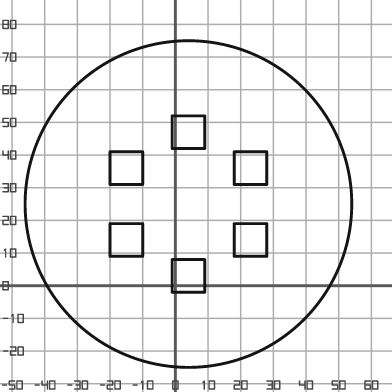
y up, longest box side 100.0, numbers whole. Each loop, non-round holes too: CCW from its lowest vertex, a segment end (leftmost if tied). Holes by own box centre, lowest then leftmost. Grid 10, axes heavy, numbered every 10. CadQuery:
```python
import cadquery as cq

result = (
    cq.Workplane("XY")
    .moveTo(4.0, 25.0)
    .circle(50.0)
    .moveTo(-1.0, -2.0)
    .lineTo(9.0, -2.0)
    .lineTo(9.0, 8.0)
    .lineTo(-1.0, 8.0)
    .close()
    .moveTo(-20.0, 9.0)
    .lineTo(-10.0, 9.0)
    .lineTo(-10.0, 19.0)
    .lineTo(-20.0, 19.0)
    .close()
    .moveTo(18.0, 9.0)
    .lineTo(28.0, 9.0)
    .lineTo(28.0, 19.0)
    .lineTo(18.0, 19.0)
    .close()
    .moveTo(-20.0, 31.0)
    .lineTo(-10.0, 31.0)
    .lineTo(-10.0, 41.0)
    .lineTo(-20.0, 41.0)
    .close()
    .moveTo(18.0, 31.0)
    .lineTo(28.0, 31.0)
    .lineTo(28.0, 41.0)
    .lineTo(18.0, 41.0)
    .close()
    .moveTo(-1.0, 42.0)
    .lineTo(9.0, 42.0)
    .lineTo(9.0, 52.0)
    .lineTo(-1.0, 52.0)
    .close()
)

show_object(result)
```